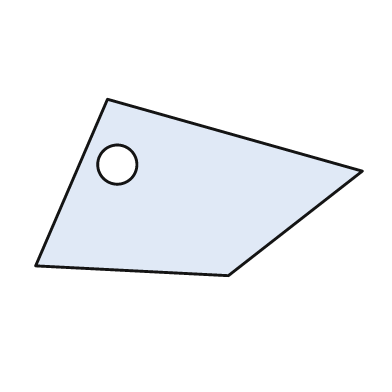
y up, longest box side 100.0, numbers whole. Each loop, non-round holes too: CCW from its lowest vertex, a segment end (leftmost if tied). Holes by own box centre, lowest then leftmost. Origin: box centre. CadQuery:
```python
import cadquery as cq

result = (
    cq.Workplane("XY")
    .moveTo(9.0, -27.0)
    .lineTo(50.0, 5.0)
    .lineTo(-28.0, 27.0)
    .lineTo(-50.0, -24.0)
    .close()
    .moveTo(-25.0, 7.0)
    .circle(6.0)
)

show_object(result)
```